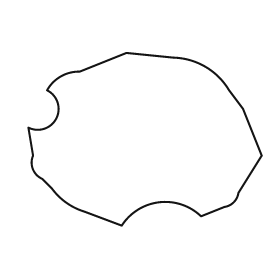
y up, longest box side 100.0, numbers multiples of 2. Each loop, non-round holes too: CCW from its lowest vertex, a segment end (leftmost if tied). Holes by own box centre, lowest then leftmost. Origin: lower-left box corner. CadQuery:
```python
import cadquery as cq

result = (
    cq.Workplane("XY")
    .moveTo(40.0, 0.0)
    .threePointArc((56.0, 10.0), (74.0, 4.0))
    .lineTo(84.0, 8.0)
    .threePointArc((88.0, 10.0), (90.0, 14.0))
    .lineTo(100.0, 30.0)
    .lineTo(92.0, 50.0)
    .lineTo(86.0, 58.0)
    .threePointArc((76.0, 68.0), (62.0, 72.0))
    .lineTo(42.0, 74.0)
    .lineTo(22.0, 66.0)
    .threePointArc((14.0, 64.0), (8.0, 58.0))
    .threePointArc((12.0, 46.0), (0.0, 42.0))
    .lineTo(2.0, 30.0)
    .threePointArc((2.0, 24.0), (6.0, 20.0))
    .lineTo(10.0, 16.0)
    .threePointArc((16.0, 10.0), (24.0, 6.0))
    .close()
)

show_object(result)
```